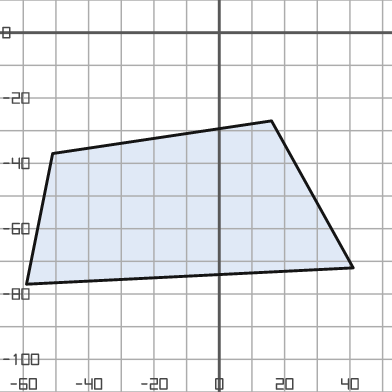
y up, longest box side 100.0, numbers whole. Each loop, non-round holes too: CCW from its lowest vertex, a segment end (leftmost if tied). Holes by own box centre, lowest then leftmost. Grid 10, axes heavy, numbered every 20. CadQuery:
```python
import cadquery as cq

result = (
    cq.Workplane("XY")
    .moveTo(-59.0, -77.0)
    .lineTo(41.0, -72.0)
    .lineTo(16.0, -27.0)
    .lineTo(-51.0, -37.0)
    .close()
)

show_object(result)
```